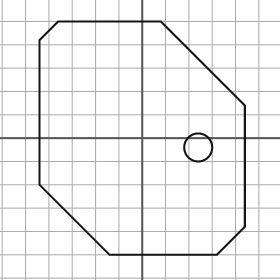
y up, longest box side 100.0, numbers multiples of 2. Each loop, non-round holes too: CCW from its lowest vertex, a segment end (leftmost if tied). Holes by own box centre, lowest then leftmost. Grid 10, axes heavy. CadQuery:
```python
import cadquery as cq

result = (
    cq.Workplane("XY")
    .moveTo(-14.0, -50.0)
    .lineTo(32.0, -50.0)
    .lineTo(44.0, -38.0)
    .lineTo(44.0, 14.0)
    .lineTo(8.0, 50.0)
    .lineTo(-36.0, 50.0)
    .lineTo(-44.0, 42.0)
    .lineTo(-44.0, -20.0)
    .close()
    .moveTo(24.0, -4.0)
    .circle(6.0)
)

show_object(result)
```